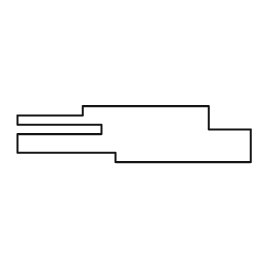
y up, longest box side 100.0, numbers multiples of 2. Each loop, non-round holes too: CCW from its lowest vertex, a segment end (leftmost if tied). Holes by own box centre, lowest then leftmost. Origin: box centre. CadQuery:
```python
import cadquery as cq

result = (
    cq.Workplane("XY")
    .moveTo(-8.0, -12.0)
    .lineTo(50.0, -12.0)
    .lineTo(50.0, 2.0)
    .lineTo(32.0, 2.0)
    .lineTo(32.0, 12.0)
    .lineTo(-22.0, 12.0)
    .lineTo(-22.0, 8.0)
    .lineTo(-50.0, 8.0)
    .lineTo(-50.0, 4.0)
    .lineTo(-14.0, 4.0)
    .lineTo(-14.0, 0.0)
    .lineTo(-50.0, 0.0)
    .lineTo(-50.0, -8.0)
    .lineTo(-8.0, -8.0)
    .close()
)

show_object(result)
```